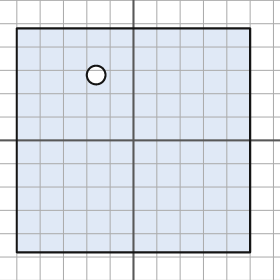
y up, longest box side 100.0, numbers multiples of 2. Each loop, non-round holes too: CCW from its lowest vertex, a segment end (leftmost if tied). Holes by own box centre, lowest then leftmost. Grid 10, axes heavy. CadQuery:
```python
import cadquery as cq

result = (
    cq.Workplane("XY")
    .moveTo(-50.0, -48.0)
    .lineTo(50.0, -48.0)
    .lineTo(50.0, 48.0)
    .lineTo(-50.0, 48.0)
    .close()
    .moveTo(-16.0, 28.0)
    .circle(4.0)
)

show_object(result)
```